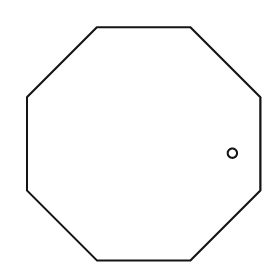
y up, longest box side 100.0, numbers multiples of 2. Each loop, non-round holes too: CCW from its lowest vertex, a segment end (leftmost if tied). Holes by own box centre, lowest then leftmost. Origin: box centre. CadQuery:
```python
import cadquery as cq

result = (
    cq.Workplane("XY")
    .moveTo(-20.0, -50.0)
    .lineTo(20.0, -50.0)
    .lineTo(50.0, -20.0)
    .lineTo(50.0, 20.0)
    .lineTo(20.0, 50.0)
    .lineTo(-20.0, 50.0)
    .lineTo(-50.0, 20.0)
    .lineTo(-50.0, -20.0)
    .close()
    .moveTo(38.0, -4.0)
    .circle(2.0)
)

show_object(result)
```